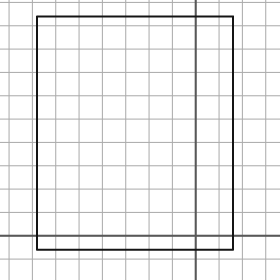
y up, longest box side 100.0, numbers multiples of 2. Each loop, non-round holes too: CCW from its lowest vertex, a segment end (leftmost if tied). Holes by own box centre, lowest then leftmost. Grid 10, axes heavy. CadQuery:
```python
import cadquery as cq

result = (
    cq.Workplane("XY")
    .moveTo(-68.0, -6.0)
    .lineTo(16.0, -6.0)
    .lineTo(16.0, 94.0)
    .lineTo(-68.0, 94.0)
    .close()
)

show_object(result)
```